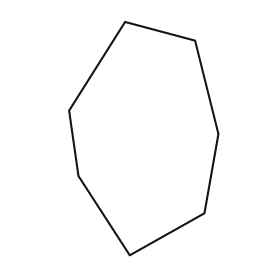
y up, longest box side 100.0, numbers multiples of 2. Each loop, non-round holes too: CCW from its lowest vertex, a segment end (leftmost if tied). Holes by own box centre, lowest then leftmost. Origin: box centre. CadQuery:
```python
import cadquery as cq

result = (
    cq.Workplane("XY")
    .moveTo(-6.0, -50.0)
    .lineTo(26.0, -32.0)
    .lineTo(32.0, 2.0)
    .lineTo(22.0, 42.0)
    .lineTo(-8.0, 50.0)
    .lineTo(-32.0, 12.0)
    .lineTo(-28.0, -16.0)
    .close()
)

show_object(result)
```